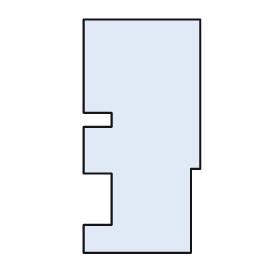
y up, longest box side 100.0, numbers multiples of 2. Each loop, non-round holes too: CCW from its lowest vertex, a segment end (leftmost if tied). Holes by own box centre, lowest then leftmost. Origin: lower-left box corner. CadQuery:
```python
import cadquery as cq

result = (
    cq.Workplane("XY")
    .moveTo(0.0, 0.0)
    .lineTo(46.0, 0.0)
    .lineTo(46.0, 36.0)
    .lineTo(50.0, 36.0)
    .lineTo(50.0, 100.0)
    .lineTo(0.0, 100.0)
    .lineTo(0.0, 60.0)
    .lineTo(12.0, 60.0)
    .lineTo(12.0, 54.0)
    .lineTo(0.0, 54.0)
    .lineTo(0.0, 34.0)
    .lineTo(12.0, 34.0)
    .lineTo(12.0, 12.0)
    .lineTo(0.0, 12.0)
    .close()
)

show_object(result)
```